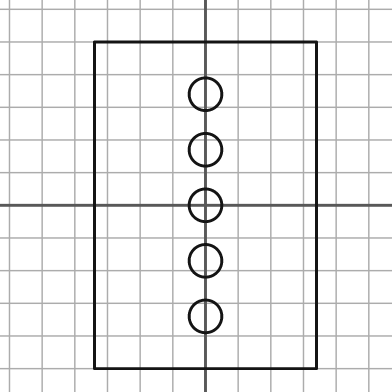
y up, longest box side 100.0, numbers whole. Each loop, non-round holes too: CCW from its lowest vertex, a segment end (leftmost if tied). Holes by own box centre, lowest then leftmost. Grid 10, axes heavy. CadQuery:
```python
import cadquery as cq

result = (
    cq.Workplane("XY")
    .moveTo(-34.0, -50.0)
    .lineTo(34.0, -50.0)
    .lineTo(34.0, 50.0)
    .lineTo(-34.0, 50.0)
    .close()
    .moveTo(0.0, -34.0)
    .circle(5.0)
    .moveTo(0.0, -17.0)
    .circle(5.0)
    .moveTo(0.0, 0.0)
    .circle(5.0)
    .moveTo(0.0, 17.0)
    .circle(5.0)
    .moveTo(0.0, 34.0)
    .circle(5.0)
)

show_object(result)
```